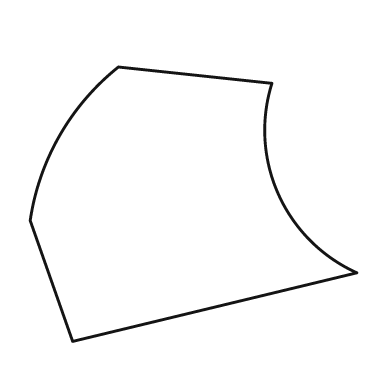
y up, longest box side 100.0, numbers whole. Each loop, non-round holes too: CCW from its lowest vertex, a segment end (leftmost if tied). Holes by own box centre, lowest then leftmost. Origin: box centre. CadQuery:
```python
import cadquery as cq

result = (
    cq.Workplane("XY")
    .moveTo(-37.0, -42.0)
    .lineTo(50.0, -21.0)
    .threePointArc((26.0, 3.0), (24.0, 37.0))
    .lineTo(-23.0, 42.0)
    .threePointArc((-41.0, 21.0), (-50.0, -5.0))
    .close()
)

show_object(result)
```